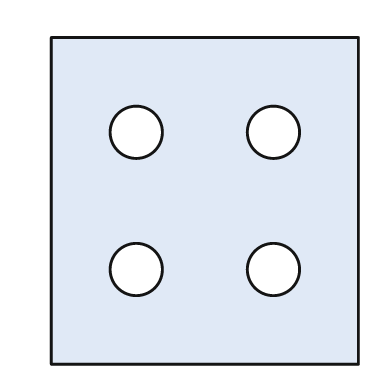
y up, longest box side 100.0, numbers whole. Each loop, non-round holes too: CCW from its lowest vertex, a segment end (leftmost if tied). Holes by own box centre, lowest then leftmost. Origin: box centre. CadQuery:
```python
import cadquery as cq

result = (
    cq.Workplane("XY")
    .moveTo(-47.0, -50.0)
    .lineTo(47.0, -50.0)
    .lineTo(47.0, 50.0)
    .lineTo(-47.0, 50.0)
    .close()
    .moveTo(-21.0, -21.0)
    .circle(8.0)
    .moveTo(21.0, -21.0)
    .circle(8.0)
    .moveTo(-21.0, 21.0)
    .circle(8.0)
    .moveTo(21.0, 21.0)
    .circle(8.0)
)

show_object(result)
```